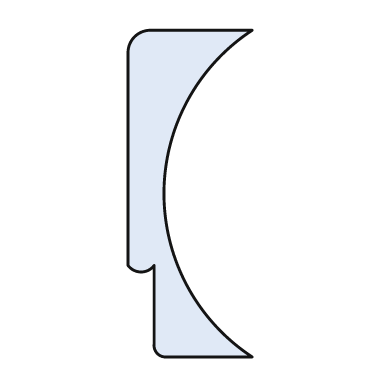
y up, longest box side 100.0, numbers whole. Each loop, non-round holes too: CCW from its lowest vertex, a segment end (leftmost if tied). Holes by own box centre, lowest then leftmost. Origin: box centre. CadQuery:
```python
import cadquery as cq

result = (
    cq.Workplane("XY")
    .moveTo(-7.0, -50.0)
    .lineTo(19.0, -50.0)
    .threePointArc((-8.0, 0.0), (19.0, 50.0))
    .lineTo(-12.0, 50.0)
    .threePointArc((-17.0, 48.0), (-19.0, 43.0))
    .lineTo(-19.0, -22.0)
    .threePointArc((-15.0, -24.0), (-11.0, -22.0))
    .lineTo(-11.0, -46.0)
    .threePointArc((-10.0, -49.0), (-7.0, -50.0))
    .close()
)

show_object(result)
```